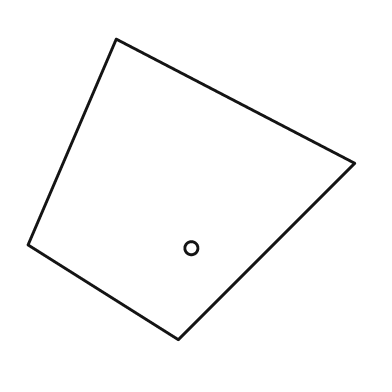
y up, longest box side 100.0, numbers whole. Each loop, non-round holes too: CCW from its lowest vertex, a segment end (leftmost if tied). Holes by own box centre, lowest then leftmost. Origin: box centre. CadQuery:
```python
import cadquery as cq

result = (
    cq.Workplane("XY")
    .moveTo(-4.0, -46.0)
    .lineTo(50.0, 8.0)
    .lineTo(-23.0, 46.0)
    .lineTo(-50.0, -17.0)
    .close()
    .moveTo(0.0, -18.0)
    .circle(2.0)
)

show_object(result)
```